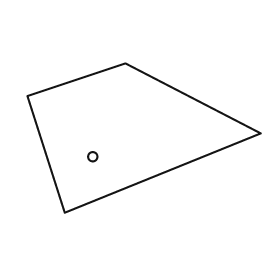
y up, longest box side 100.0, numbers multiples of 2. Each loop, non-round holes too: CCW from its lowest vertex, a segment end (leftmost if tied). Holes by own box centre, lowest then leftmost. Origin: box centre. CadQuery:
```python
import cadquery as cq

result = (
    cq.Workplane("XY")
    .moveTo(-34.0, -32.0)
    .lineTo(50.0, 2.0)
    .lineTo(-8.0, 32.0)
    .lineTo(-50.0, 18.0)
    .close()
    .moveTo(-22.0, -8.0)
    .circle(2.0)
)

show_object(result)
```